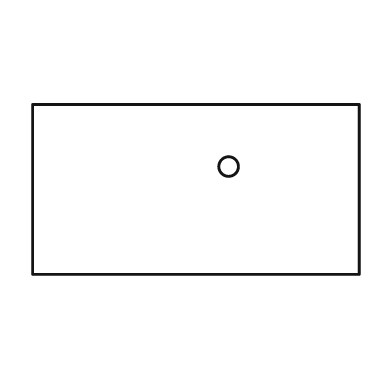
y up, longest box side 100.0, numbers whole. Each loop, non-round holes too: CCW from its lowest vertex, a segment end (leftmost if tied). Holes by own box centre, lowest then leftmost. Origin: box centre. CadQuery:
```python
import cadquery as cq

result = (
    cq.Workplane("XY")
    .moveTo(-50.0, -26.0)
    .lineTo(50.0, -26.0)
    .lineTo(50.0, 26.0)
    .lineTo(-50.0, 26.0)
    .close()
    .moveTo(10.0, 7.0)
    .circle(3.0)
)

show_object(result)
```